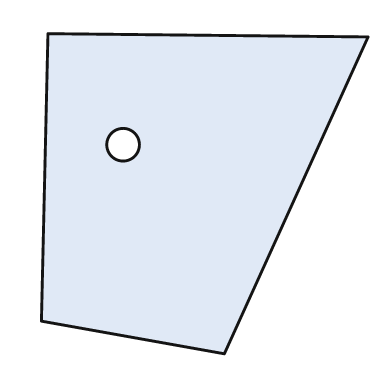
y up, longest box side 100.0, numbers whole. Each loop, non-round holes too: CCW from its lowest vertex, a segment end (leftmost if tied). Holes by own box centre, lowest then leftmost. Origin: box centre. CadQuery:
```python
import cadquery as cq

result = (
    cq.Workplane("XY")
    .moveTo(6.0, -49.0)
    .lineTo(50.0, 48.0)
    .lineTo(-48.0, 49.0)
    .lineTo(-50.0, -39.0)
    .close()
    .moveTo(-25.0, 15.0)
    .circle(5.0)
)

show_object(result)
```